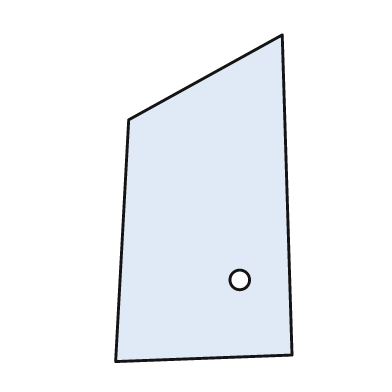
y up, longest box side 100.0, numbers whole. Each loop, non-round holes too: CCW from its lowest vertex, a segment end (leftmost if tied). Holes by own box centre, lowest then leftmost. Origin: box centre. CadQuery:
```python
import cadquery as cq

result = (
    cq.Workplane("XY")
    .moveTo(-27.0, -50.0)
    .lineTo(27.0, -48.0)
    .lineTo(24.0, 50.0)
    .lineTo(-23.0, 24.0)
    .close()
    .moveTo(11.0, -25.0)
    .circle(3.0)
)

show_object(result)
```